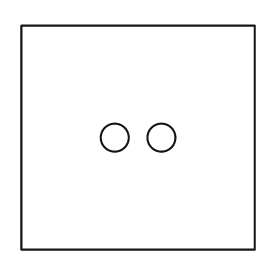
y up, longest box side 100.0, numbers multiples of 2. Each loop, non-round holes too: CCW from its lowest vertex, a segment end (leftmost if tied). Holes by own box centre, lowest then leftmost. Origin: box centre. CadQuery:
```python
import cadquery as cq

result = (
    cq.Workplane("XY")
    .moveTo(-50.0, -48.0)
    .lineTo(50.0, -48.0)
    .lineTo(50.0, 48.0)
    .lineTo(-50.0, 48.0)
    .close()
    .moveTo(-10.0, 0.0)
    .circle(6.0)
    .moveTo(10.0, 0.0)
    .circle(6.0)
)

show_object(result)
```